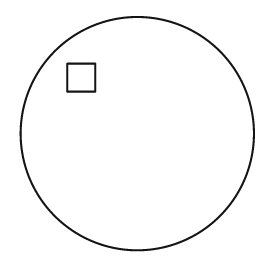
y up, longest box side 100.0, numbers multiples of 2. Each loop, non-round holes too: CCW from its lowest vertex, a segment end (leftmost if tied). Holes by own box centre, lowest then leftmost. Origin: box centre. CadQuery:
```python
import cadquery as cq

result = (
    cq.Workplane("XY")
    .moveTo(0.0, 0.0)
    .circle(50.0)
    .moveTo(-30.0, 18.0)
    .lineTo(-18.0, 18.0)
    .lineTo(-18.0, 30.0)
    .lineTo(-30.0, 30.0)
    .close()
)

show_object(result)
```